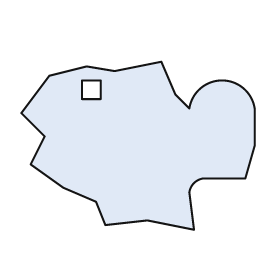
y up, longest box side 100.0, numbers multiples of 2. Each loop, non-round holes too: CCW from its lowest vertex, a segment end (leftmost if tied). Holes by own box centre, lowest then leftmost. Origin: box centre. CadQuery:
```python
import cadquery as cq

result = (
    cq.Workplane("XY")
    .moveTo(24.0, -36.0)
    .lineTo(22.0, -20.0)
    .threePointArc((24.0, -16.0), (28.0, -14.0))
    .lineTo(46.0, -14.0)
    .lineTo(50.0, 0.0)
    .lineTo(50.0, 16.0)
    .threePointArc((36.0, 28.0), (22.0, 16.0))
    .lineTo(16.0, 22.0)
    .lineTo(10.0, 36.0)
    .lineTo(-10.0, 32.0)
    .lineTo(-22.0, 34.0)
    .lineTo(-38.0, 30.0)
    .lineTo(-50.0, 14.0)
    .lineTo(-40.0, 4.0)
    .lineTo(-46.0, -8.0)
    .lineTo(-32.0, -18.0)
    .lineTo(-18.0, -24.0)
    .lineTo(-14.0, -34.0)
    .lineTo(4.0, -32.0)
    .close()
    .moveTo(-24.0, 20.0)
    .lineTo(-16.0, 20.0)
    .lineTo(-16.0, 28.0)
    .lineTo(-24.0, 28.0)
    .close()
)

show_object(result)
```